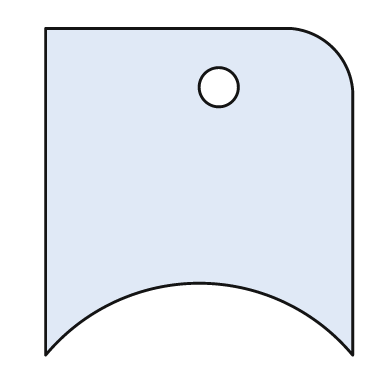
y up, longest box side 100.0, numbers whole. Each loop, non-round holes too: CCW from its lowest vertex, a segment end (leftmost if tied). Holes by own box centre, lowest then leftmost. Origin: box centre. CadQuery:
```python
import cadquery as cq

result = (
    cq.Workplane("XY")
    .moveTo(-47.0, -50.0)
    .threePointArc((0.0, -28.0), (47.0, -50.0))
    .lineTo(47.0, 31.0)
    .threePointArc((41.0, 44.0), (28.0, 50.0))
    .lineTo(-47.0, 50.0)
    .close()
    .moveTo(6.0, 32.0)
    .circle(6.0)
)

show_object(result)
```